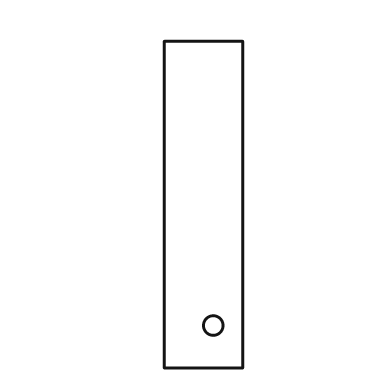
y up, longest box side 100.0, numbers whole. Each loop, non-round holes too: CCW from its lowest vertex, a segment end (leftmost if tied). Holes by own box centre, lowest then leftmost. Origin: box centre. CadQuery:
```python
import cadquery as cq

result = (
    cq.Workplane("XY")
    .moveTo(-12.0, -50.0)
    .lineTo(12.0, -50.0)
    .lineTo(12.0, 50.0)
    .lineTo(-12.0, 50.0)
    .close()
    .moveTo(3.0, -37.0)
    .circle(3.0)
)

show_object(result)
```